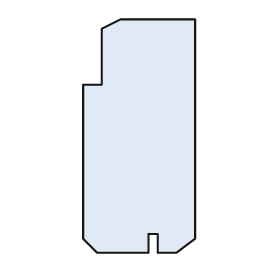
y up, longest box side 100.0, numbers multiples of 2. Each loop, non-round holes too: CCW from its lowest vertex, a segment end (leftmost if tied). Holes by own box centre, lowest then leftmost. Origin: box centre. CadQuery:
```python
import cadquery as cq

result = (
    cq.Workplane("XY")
    .moveTo(-18.0, -50.0)
    .lineTo(4.0, -50.0)
    .lineTo(4.0, -42.0)
    .lineTo(8.0, -42.0)
    .lineTo(8.0, -50.0)
    .lineTo(16.0, -50.0)
    .lineTo(24.0, -44.0)
    .lineTo(24.0, 50.0)
    .lineTo(-8.0, 50.0)
    .lineTo(-16.0, 46.0)
    .lineTo(-16.0, 22.0)
    .lineTo(-24.0, 22.0)
    .lineTo(-24.0, -44.0)
    .close()
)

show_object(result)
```